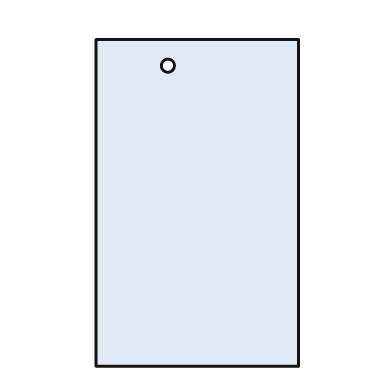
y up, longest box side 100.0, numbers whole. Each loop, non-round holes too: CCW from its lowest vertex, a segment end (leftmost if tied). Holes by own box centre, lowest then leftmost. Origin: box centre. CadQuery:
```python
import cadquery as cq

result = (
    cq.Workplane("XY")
    .moveTo(-31.0, -50.0)
    .lineTo(31.0, -50.0)
    .lineTo(31.0, 50.0)
    .lineTo(-31.0, 50.0)
    .close()
    .moveTo(-9.0, 42.0)
    .circle(2.0)
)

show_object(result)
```